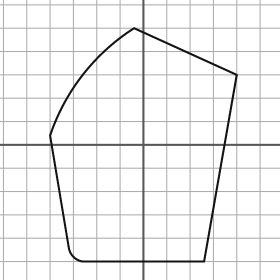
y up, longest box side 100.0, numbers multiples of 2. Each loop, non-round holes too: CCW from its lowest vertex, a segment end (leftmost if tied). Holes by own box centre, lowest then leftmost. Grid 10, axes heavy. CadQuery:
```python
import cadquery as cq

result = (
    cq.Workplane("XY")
    .moveTo(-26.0, -50.0)
    .lineTo(26.0, -50.0)
    .lineTo(40.0, 30.0)
    .lineTo(-4.0, 50.0)
    .threePointArc((-26.0, 30.0), (-40.0, 4.0))
    .lineTo(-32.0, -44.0)
    .threePointArc((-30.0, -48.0), (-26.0, -50.0))
    .close()
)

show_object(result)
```